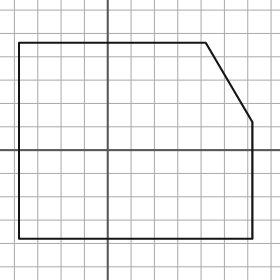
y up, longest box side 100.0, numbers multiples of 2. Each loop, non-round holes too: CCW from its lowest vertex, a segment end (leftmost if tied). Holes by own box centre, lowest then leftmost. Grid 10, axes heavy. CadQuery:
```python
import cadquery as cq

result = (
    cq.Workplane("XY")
    .moveTo(-38.0, -38.0)
    .lineTo(62.0, -38.0)
    .lineTo(62.0, 12.0)
    .lineTo(42.0, 46.0)
    .lineTo(-38.0, 46.0)
    .close()
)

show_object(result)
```